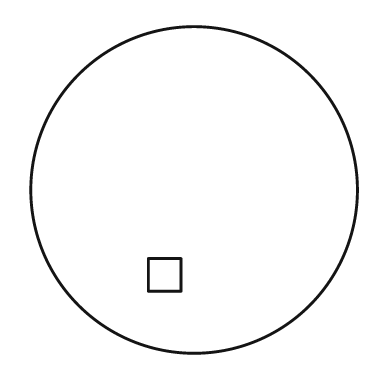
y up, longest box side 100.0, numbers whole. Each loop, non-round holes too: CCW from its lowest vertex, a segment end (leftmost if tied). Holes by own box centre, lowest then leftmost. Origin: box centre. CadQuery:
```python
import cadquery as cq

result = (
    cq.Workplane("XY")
    .moveTo(0.0, 0.0)
    .circle(50.0)
    .moveTo(-14.0, -31.0)
    .lineTo(-4.0, -31.0)
    .lineTo(-4.0, -21.0)
    .lineTo(-14.0, -21.0)
    .close()
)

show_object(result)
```